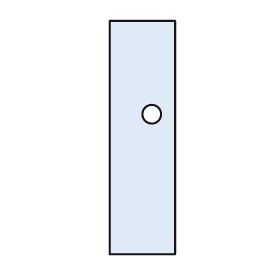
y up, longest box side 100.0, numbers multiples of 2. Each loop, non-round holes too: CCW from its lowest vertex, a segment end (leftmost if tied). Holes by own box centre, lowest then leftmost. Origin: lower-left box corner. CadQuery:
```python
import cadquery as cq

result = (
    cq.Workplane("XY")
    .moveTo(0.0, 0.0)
    .lineTo(28.0, 0.0)
    .lineTo(28.0, 100.0)
    .lineTo(0.0, 100.0)
    .close()
    .moveTo(18.0, 60.0)
    .circle(4.0)
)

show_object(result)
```